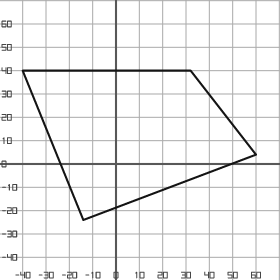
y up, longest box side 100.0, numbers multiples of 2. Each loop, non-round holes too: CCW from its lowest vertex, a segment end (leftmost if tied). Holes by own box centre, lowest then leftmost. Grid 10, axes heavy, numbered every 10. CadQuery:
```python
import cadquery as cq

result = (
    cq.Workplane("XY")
    .moveTo(-14.0, -24.0)
    .lineTo(60.0, 4.0)
    .lineTo(32.0, 40.0)
    .lineTo(-40.0, 40.0)
    .close()
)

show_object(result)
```